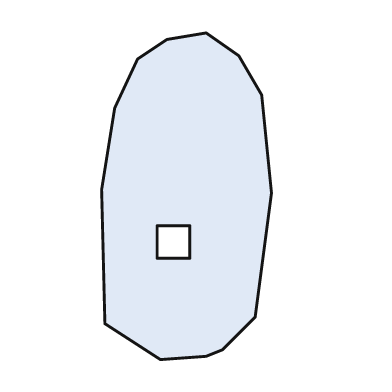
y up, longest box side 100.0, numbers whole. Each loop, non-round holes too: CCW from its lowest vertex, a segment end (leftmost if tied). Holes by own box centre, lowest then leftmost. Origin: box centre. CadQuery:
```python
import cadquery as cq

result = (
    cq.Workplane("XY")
    .moveTo(-8.0, -50.0)
    .lineTo(6.0, -49.0)
    .lineTo(11.0, -47.0)
    .lineTo(21.0, -37.0)
    .lineTo(26.0, 1.0)
    .lineTo(23.0, 31.0)
    .lineTo(16.0, 43.0)
    .lineTo(6.0, 50.0)
    .lineTo(-6.0, 48.0)
    .lineTo(-15.0, 42.0)
    .lineTo(-22.0, 27.0)
    .lineTo(-26.0, 2.0)
    .lineTo(-25.0, -39.0)
    .close()
    .moveTo(-9.0, -19.0)
    .lineTo(1.0, -19.0)
    .lineTo(1.0, -9.0)
    .lineTo(-9.0, -9.0)
    .close()
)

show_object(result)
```